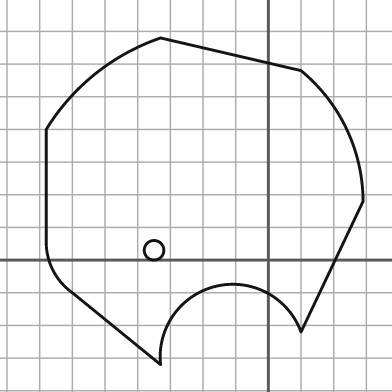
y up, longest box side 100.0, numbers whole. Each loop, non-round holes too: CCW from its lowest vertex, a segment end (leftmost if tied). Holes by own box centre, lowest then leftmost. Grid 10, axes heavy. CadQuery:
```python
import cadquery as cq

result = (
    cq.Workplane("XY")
    .moveTo(-33.0, -32.0)
    .threePointArc((-16.0, -8.0), (10.0, -22.0))
    .lineTo(29.0, 18.0)
    .threePointArc((24.0, 40.0), (10.0, 58.0))
    .lineTo(-33.0, 68.0)
    .threePointArc((-53.0, 57.0), (-68.0, 40.0))
    .lineTo(-68.0, 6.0)
    .threePointArc((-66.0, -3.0), (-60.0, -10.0))
    .close()
    .moveTo(-35.0, 3.0)
    .circle(3.0)
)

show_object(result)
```